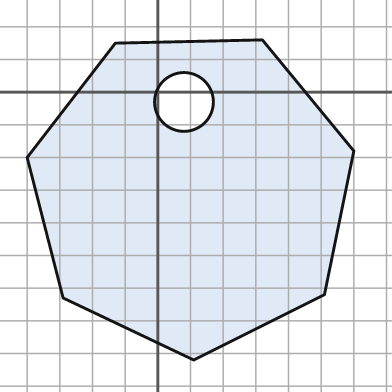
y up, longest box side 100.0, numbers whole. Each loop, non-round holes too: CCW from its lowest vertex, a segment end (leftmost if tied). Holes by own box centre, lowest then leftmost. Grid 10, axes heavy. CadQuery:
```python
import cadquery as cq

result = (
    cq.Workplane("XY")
    .moveTo(11.0, -82.0)
    .lineTo(51.0, -62.0)
    .lineTo(60.0, -18.0)
    .lineTo(32.0, 16.0)
    .lineTo(-13.0, 15.0)
    .lineTo(-40.0, -20.0)
    .lineTo(-29.0, -63.0)
    .close()
    .moveTo(8.0, -3.0)
    .circle(9.0)
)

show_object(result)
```